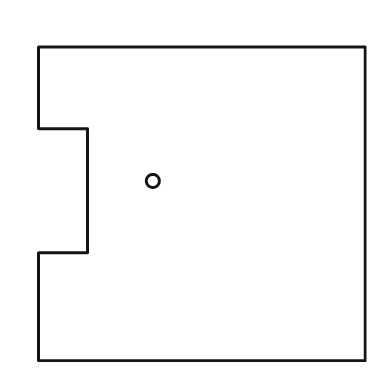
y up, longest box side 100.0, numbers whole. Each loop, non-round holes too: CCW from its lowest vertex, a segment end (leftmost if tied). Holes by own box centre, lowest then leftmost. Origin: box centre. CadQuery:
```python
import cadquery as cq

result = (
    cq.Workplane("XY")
    .moveTo(-50.0, -48.0)
    .lineTo(50.0, -48.0)
    .lineTo(50.0, 48.0)
    .lineTo(-50.0, 48.0)
    .lineTo(-50.0, 23.0)
    .lineTo(-35.0, 23.0)
    .lineTo(-35.0, -15.0)
    .lineTo(-50.0, -15.0)
    .close()
    .moveTo(-15.0, 7.0)
    .circle(2.0)
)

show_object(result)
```